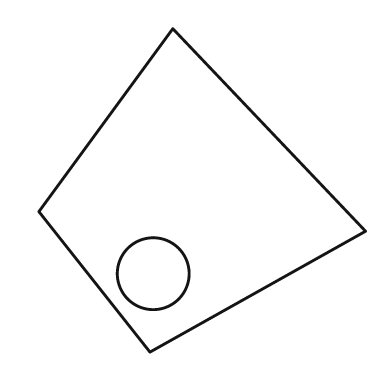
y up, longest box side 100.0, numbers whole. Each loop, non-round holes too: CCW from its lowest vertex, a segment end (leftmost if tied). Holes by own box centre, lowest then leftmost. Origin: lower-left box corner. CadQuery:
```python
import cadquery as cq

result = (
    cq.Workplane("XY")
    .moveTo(34.0, 0.0)
    .lineTo(100.0, 37.0)
    .lineTo(41.0, 99.0)
    .lineTo(0.0, 43.0)
    .close()
    .moveTo(35.0, 24.0)
    .circle(11.0)
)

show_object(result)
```